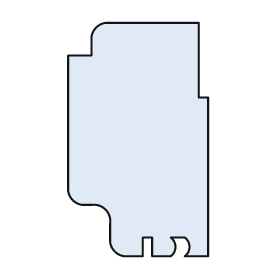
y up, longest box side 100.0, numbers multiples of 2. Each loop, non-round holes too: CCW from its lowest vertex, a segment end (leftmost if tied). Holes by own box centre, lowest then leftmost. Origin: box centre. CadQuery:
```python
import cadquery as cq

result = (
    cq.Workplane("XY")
    .moveTo(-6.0, -50.0)
    .lineTo(2.0, -50.0)
    .lineTo(2.0, -42.0)
    .lineTo(6.0, -42.0)
    .lineTo(6.0, -50.0)
    .lineTo(14.0, -50.0)
    .threePointArc((16.0, -46.0), (14.0, -42.0))
    .lineTo(20.0, -42.0)
    .threePointArc((22.0, -46.0), (20.0, -50.0))
    .lineTo(30.0, -50.0)
    .lineTo(30.0, 18.0)
    .lineTo(26.0, 18.0)
    .lineTo(26.0, 50.0)
    .lineTo(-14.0, 50.0)
    .threePointArc((-18.0, 48.0), (-20.0, 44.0))
    .lineTo(-20.0, 36.0)
    .lineTo(-30.0, 36.0)
    .lineTo(-30.0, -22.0)
    .threePointArc((-28.0, -26.0), (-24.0, -28.0))
    .lineTo(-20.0, -28.0)
    .threePointArc((-14.0, -30.0), (-12.0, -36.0))
    .lineTo(-12.0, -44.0)
    .threePointArc((-10.0, -48.0), (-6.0, -50.0))
    .close()
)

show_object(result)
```